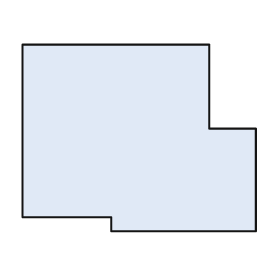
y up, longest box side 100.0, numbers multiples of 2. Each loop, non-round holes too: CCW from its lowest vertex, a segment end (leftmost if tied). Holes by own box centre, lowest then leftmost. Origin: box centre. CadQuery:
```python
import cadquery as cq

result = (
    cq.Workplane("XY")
    .moveTo(-12.0, -40.0)
    .lineTo(50.0, -40.0)
    .lineTo(50.0, 4.0)
    .lineTo(30.0, 4.0)
    .lineTo(30.0, 40.0)
    .lineTo(-50.0, 40.0)
    .lineTo(-50.0, -34.0)
    .lineTo(-12.0, -34.0)
    .close()
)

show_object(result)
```